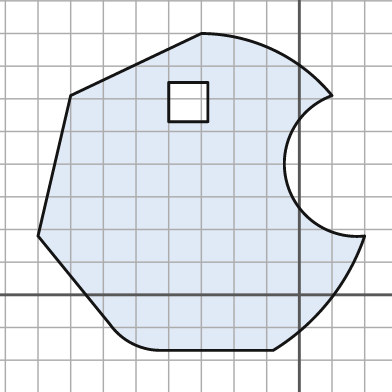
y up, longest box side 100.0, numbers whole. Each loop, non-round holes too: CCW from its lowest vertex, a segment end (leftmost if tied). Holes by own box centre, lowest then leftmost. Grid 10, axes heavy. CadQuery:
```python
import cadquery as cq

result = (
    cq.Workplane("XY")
    .moveTo(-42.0, -17.0)
    .lineTo(-8.0, -17.0)
    .threePointArc((9.0, -2.0), (20.0, 18.0))
    .threePointArc((-4.0, 35.0), (10.0, 61.0))
    .threePointArc((-8.0, 75.0), (-30.0, 80.0))
    .lineTo(-70.0, 61.0)
    .lineTo(-80.0, 18.0)
    .lineTo(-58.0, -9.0)
    .threePointArc((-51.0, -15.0), (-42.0, -17.0))
    .close()
    .moveTo(-40.0, 53.0)
    .lineTo(-28.0, 53.0)
    .lineTo(-28.0, 65.0)
    .lineTo(-40.0, 65.0)
    .close()
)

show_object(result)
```